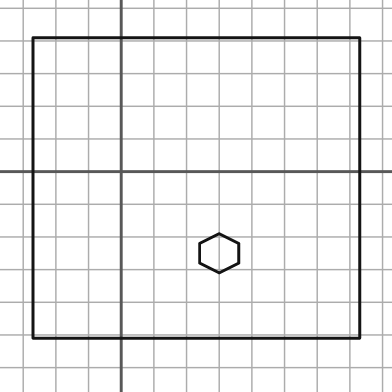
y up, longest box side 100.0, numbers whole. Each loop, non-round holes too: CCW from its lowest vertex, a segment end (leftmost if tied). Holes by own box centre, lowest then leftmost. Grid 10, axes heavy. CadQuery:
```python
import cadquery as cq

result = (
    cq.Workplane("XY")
    .moveTo(-27.0, -51.0)
    .lineTo(73.0, -51.0)
    .lineTo(73.0, 41.0)
    .lineTo(-27.0, 41.0)
    .close()
    .moveTo(30.0, -31.0)
    .lineTo(36.0, -28.0)
    .lineTo(36.0, -22.0)
    .lineTo(30.0, -19.0)
    .lineTo(24.0, -22.0)
    .lineTo(24.0, -28.0)
    .close()
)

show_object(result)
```